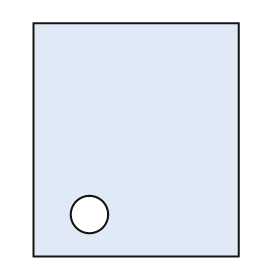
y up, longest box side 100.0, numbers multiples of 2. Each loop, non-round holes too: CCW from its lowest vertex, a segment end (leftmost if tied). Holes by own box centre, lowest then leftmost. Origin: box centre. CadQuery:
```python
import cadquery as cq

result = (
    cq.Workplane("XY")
    .moveTo(-44.0, -50.0)
    .lineTo(44.0, -50.0)
    .lineTo(44.0, 50.0)
    .lineTo(-44.0, 50.0)
    .close()
    .moveTo(-20.0, -32.0)
    .circle(8.0)
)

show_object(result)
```